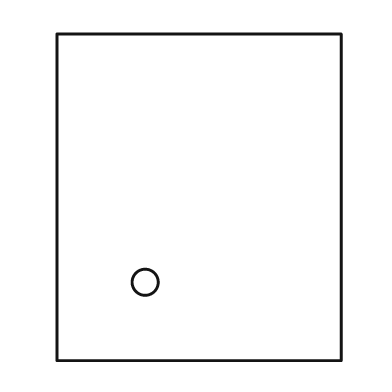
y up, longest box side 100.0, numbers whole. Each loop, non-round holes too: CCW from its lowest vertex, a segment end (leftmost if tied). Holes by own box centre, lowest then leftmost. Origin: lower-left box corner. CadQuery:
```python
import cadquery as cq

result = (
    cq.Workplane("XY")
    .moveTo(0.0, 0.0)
    .lineTo(87.0, 0.0)
    .lineTo(87.0, 100.0)
    .lineTo(0.0, 100.0)
    .close()
    .moveTo(27.0, 24.0)
    .circle(4.0)
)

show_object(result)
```